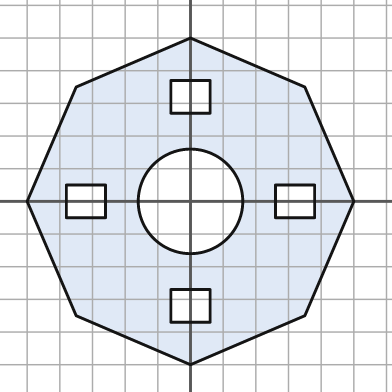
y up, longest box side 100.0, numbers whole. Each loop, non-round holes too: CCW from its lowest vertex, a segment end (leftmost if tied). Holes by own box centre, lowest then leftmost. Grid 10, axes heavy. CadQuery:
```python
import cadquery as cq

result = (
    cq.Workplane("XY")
    .moveTo(0.0, -50.0)
    .lineTo(35.0, -35.0)
    .lineTo(50.0, 0.0)
    .lineTo(35.0, 35.0)
    .lineTo(0.0, 50.0)
    .lineTo(-35.0, 35.0)
    .lineTo(-50.0, 0.0)
    .lineTo(-35.0, -35.0)
    .close()
    .moveTo(-6.0, -37.0)
    .lineTo(6.0, -37.0)
    .lineTo(6.0, -27.0)
    .lineTo(-6.0, -27.0)
    .close()
    .moveTo(-38.0, -5.0)
    .lineTo(-26.0, -5.0)
    .lineTo(-26.0, 5.0)
    .lineTo(-38.0, 5.0)
    .close()
    .moveTo(0.0, 0.0)
    .circle(16.0)
    .moveTo(26.0, -5.0)
    .lineTo(38.0, -5.0)
    .lineTo(38.0, 5.0)
    .lineTo(26.0, 5.0)
    .close()
    .moveTo(-6.0, 27.0)
    .lineTo(6.0, 27.0)
    .lineTo(6.0, 37.0)
    .lineTo(-6.0, 37.0)
    .close()
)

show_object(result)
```